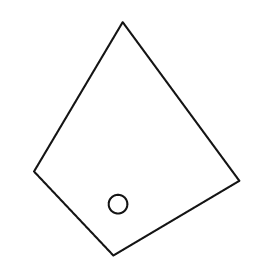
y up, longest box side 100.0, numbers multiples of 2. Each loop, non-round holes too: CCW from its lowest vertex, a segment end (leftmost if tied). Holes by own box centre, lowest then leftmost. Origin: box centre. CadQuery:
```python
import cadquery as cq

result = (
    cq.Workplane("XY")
    .moveTo(-10.0, -50.0)
    .lineTo(44.0, -18.0)
    .lineTo(-6.0, 50.0)
    .lineTo(-44.0, -14.0)
    .close()
    .moveTo(-8.0, -28.0)
    .circle(4.0)
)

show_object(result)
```